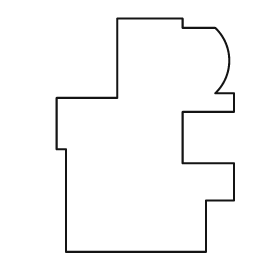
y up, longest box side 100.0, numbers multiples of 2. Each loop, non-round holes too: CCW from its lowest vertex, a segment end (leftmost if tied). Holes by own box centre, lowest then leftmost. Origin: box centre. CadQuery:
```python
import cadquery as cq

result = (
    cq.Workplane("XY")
    .moveTo(-34.0, -50.0)
    .lineTo(26.0, -50.0)
    .lineTo(26.0, -28.0)
    .lineTo(38.0, -28.0)
    .lineTo(38.0, -12.0)
    .lineTo(16.0, -12.0)
    .lineTo(16.0, 10.0)
    .lineTo(38.0, 10.0)
    .lineTo(38.0, 18.0)
    .lineTo(30.0, 18.0)
    .threePointArc((36.0, 32.0), (30.0, 46.0))
    .lineTo(16.0, 46.0)
    .lineTo(16.0, 50.0)
    .lineTo(-12.0, 50.0)
    .lineTo(-12.0, 16.0)
    .lineTo(-38.0, 16.0)
    .lineTo(-38.0, -6.0)
    .lineTo(-34.0, -6.0)
    .close()
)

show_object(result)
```